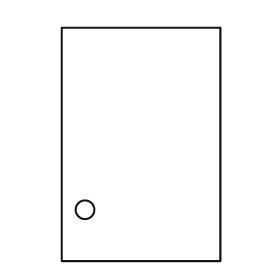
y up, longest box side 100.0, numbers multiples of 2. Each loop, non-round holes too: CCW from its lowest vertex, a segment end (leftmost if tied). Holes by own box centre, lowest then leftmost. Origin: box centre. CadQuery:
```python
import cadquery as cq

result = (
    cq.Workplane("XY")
    .moveTo(-34.0, -50.0)
    .lineTo(34.0, -50.0)
    .lineTo(34.0, 50.0)
    .lineTo(-34.0, 50.0)
    .close()
    .moveTo(-24.0, -28.0)
    .circle(4.0)
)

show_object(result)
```